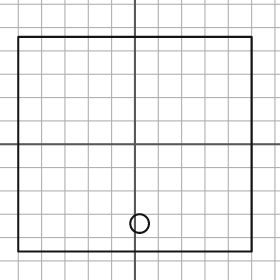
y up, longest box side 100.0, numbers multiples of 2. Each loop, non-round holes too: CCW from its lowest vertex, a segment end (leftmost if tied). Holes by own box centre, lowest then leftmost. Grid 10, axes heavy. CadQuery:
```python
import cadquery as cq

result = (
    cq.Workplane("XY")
    .moveTo(-50.0, -46.0)
    .lineTo(50.0, -46.0)
    .lineTo(50.0, 46.0)
    .lineTo(-50.0, 46.0)
    .close()
    .moveTo(2.0, -34.0)
    .circle(4.0)
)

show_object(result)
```